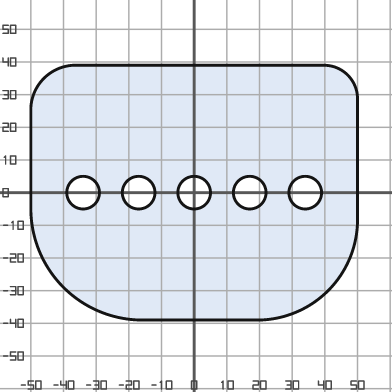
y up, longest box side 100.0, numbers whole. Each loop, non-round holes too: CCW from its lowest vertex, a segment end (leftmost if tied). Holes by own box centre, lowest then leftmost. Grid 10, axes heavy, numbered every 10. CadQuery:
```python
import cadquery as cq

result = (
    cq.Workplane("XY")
    .moveTo(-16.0, -39.0)
    .lineTo(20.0, -39.0)
    .threePointArc((41.0, -30.0), (50.0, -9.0))
    .lineTo(50.0, 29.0)
    .threePointArc((47.0, 36.0), (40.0, 39.0))
    .lineTo(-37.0, 39.0)
    .threePointArc((-46.0, 35.0), (-50.0, 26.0))
    .lineTo(-50.0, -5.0)
    .threePointArc((-40.0, -29.0), (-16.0, -39.0))
    .close()
    .moveTo(-34.0, 0.0)
    .circle(5.0)
    .moveTo(-17.0, 0.0)
    .circle(5.0)
    .moveTo(0.0, 0.0)
    .circle(5.0)
    .moveTo(17.0, 0.0)
    .circle(5.0)
    .moveTo(34.0, 0.0)
    .circle(5.0)
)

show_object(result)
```